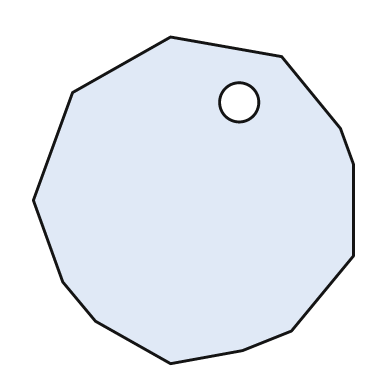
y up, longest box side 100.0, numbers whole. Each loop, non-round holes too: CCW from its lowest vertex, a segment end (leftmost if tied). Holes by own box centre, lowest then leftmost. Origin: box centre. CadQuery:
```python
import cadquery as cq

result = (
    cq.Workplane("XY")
    .moveTo(-7.0, -50.0)
    .lineTo(15.0, -46.0)
    .lineTo(30.0, -40.0)
    .lineTo(49.0, -17.0)
    .lineTo(49.0, 11.0)
    .lineTo(45.0, 22.0)
    .lineTo(27.0, 44.0)
    .lineTo(-7.0, 50.0)
    .lineTo(-37.0, 33.0)
    .lineTo(-49.0, 0.0)
    .lineTo(-40.0, -25.0)
    .lineTo(-30.0, -37.0)
    .close()
    .moveTo(14.0, 30.0)
    .circle(6.0)
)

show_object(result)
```